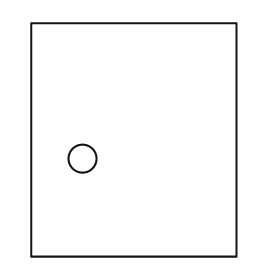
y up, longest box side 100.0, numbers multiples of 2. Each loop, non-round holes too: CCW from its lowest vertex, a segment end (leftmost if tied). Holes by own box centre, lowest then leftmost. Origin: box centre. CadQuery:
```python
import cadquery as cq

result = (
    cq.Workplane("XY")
    .moveTo(-44.0, -50.0)
    .lineTo(44.0, -50.0)
    .lineTo(44.0, 50.0)
    .lineTo(-44.0, 50.0)
    .close()
    .moveTo(-22.0, -8.0)
    .circle(6.0)
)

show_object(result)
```